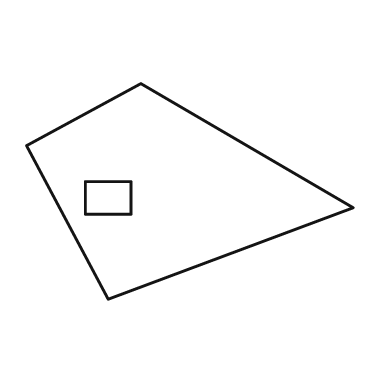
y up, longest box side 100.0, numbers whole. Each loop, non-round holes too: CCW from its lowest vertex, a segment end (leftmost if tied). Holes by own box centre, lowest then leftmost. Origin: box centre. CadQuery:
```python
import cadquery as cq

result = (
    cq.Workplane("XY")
    .moveTo(-25.0, -33.0)
    .lineTo(50.0, -5.0)
    .lineTo(-15.0, 33.0)
    .lineTo(-50.0, 14.0)
    .close()
    .moveTo(-32.0, -7.0)
    .lineTo(-18.0, -7.0)
    .lineTo(-18.0, 3.0)
    .lineTo(-32.0, 3.0)
    .close()
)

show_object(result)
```